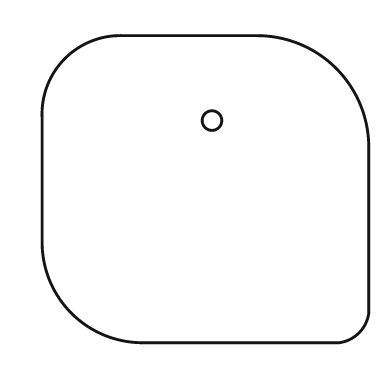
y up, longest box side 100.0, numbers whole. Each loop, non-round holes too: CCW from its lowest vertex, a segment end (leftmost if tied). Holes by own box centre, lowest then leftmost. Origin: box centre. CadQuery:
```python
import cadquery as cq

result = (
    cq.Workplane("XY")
    .moveTo(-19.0, -47.0)
    .lineTo(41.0, -47.0)
    .threePointArc((47.0, -44.0), (50.0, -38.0))
    .lineTo(50.0, 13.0)
    .threePointArc((40.0, 37.0), (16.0, 47.0))
    .lineTo(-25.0, 47.0)
    .threePointArc((-43.0, 40.0), (-50.0, 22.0))
    .lineTo(-50.0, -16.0)
    .threePointArc((-41.0, -38.0), (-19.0, -47.0))
    .close()
    .moveTo(2.0, 21.0)
    .circle(3.0)
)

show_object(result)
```